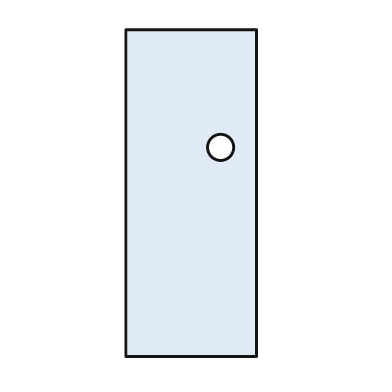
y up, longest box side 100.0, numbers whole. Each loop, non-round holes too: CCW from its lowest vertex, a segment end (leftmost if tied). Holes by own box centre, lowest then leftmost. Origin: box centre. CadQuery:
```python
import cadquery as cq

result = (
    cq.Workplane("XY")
    .moveTo(-20.0, -50.0)
    .lineTo(20.0, -50.0)
    .lineTo(20.0, 50.0)
    .lineTo(-20.0, 50.0)
    .close()
    .moveTo(9.0, 14.0)
    .circle(4.0)
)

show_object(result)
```